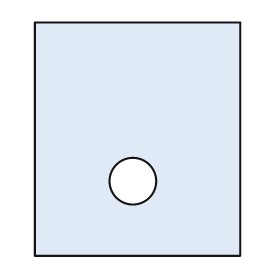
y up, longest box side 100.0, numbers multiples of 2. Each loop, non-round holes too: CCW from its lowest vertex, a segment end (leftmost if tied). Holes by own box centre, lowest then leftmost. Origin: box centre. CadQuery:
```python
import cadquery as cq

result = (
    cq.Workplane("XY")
    .moveTo(-44.0, -50.0)
    .lineTo(44.0, -50.0)
    .lineTo(44.0, 50.0)
    .lineTo(-44.0, 50.0)
    .close()
    .moveTo(-2.0, -18.0)
    .circle(10.0)
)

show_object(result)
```